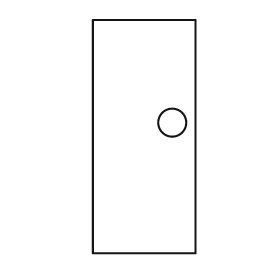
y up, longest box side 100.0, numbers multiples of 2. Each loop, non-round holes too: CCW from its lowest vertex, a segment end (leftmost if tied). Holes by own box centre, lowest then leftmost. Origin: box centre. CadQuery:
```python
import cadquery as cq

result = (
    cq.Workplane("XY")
    .moveTo(-22.0, -50.0)
    .lineTo(22.0, -50.0)
    .lineTo(22.0, 50.0)
    .lineTo(-22.0, 50.0)
    .close()
    .moveTo(12.0, 6.0)
    .circle(6.0)
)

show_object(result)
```